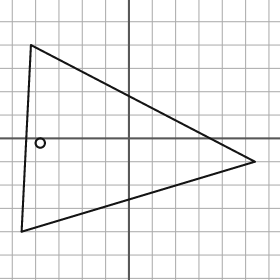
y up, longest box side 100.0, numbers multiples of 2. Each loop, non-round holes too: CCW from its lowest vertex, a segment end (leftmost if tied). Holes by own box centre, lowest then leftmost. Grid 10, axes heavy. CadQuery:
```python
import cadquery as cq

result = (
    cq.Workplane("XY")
    .moveTo(-46.0, -40.0)
    .lineTo(54.0, -10.0)
    .lineTo(-42.0, 40.0)
    .close()
    .moveTo(-38.0, -2.0)
    .circle(2.0)
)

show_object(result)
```